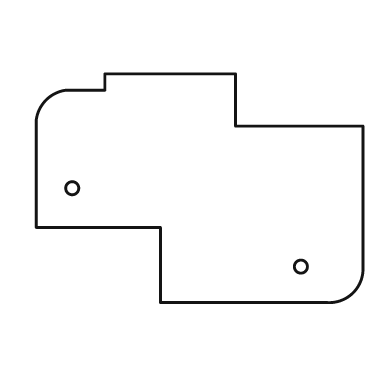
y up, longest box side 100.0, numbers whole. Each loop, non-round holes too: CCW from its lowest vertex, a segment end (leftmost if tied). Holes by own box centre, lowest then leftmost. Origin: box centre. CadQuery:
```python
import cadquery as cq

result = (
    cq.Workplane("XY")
    .moveTo(-12.0, -35.0)
    .lineTo(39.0, -35.0)
    .threePointArc((47.0, -32.0), (50.0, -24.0))
    .lineTo(50.0, 19.0)
    .lineTo(11.0, 19.0)
    .lineTo(11.0, 35.0)
    .lineTo(-29.0, 35.0)
    .lineTo(-29.0, 30.0)
    .lineTo(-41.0, 30.0)
    .threePointArc((-47.0, 27.0), (-50.0, 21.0))
    .lineTo(-50.0, -12.0)
    .lineTo(-12.0, -12.0)
    .close()
    .moveTo(31.0, -24.0)
    .circle(2.0)
    .moveTo(-39.0, 0.0)
    .circle(2.0)
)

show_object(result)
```